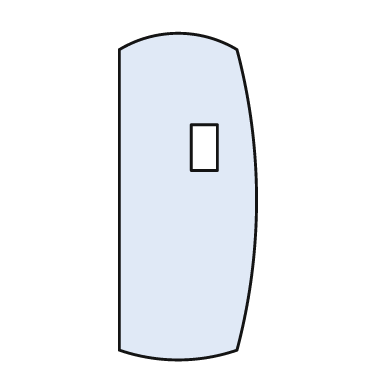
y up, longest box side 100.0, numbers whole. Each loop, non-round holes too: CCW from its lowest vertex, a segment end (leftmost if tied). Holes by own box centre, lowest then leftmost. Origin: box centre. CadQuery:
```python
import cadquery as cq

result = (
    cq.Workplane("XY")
    .moveTo(-21.0, -47.0)
    .threePointArc((-3.0, -50.0), (15.0, -47.0))
    .threePointArc((21.0, -1.0), (15.0, 45.0))
    .threePointArc((-3.0, 50.0), (-21.0, 45.0))
    .close()
    .moveTo(1.0, 8.0)
    .lineTo(9.0, 8.0)
    .lineTo(9.0, 22.0)
    .lineTo(1.0, 22.0)
    .close()
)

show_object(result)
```